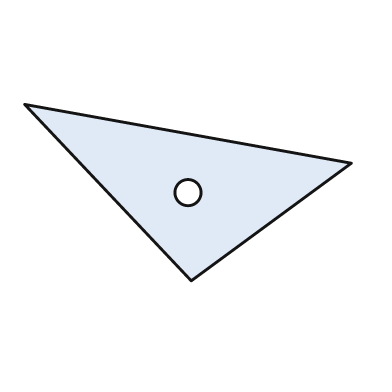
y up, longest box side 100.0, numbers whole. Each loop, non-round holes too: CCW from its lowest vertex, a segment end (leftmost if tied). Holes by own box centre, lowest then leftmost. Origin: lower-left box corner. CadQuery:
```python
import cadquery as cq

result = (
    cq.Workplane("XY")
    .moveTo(51.0, 0.0)
    .lineTo(100.0, 36.0)
    .lineTo(0.0, 54.0)
    .close()
    .moveTo(50.0, 27.0)
    .circle(4.0)
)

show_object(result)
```